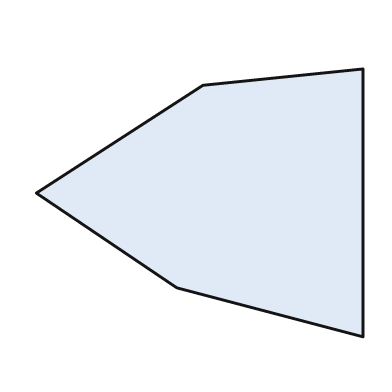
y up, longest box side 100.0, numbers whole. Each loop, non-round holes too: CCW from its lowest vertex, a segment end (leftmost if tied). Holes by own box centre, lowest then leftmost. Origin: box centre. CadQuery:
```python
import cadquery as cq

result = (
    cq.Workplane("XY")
    .moveTo(50.0, -41.0)
    .lineTo(50.0, 41.0)
    .lineTo(1.0, 36.0)
    .lineTo(-50.0, 3.0)
    .lineTo(-7.0, -26.0)
    .close()
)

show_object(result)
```